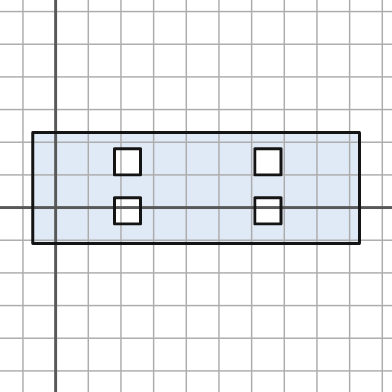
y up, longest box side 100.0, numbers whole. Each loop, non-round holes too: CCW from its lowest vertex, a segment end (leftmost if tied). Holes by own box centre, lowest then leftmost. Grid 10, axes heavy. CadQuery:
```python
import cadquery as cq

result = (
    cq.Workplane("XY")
    .moveTo(-7.0, -11.0)
    .lineTo(93.0, -11.0)
    .lineTo(93.0, 23.0)
    .lineTo(-7.0, 23.0)
    .close()
    .moveTo(18.0, -5.0)
    .lineTo(26.0, -5.0)
    .lineTo(26.0, 3.0)
    .lineTo(18.0, 3.0)
    .close()
    .moveTo(61.0, -5.0)
    .lineTo(69.0, -5.0)
    .lineTo(69.0, 3.0)
    .lineTo(61.0, 3.0)
    .close()
    .moveTo(18.0, 10.0)
    .lineTo(26.0, 10.0)
    .lineTo(26.0, 18.0)
    .lineTo(18.0, 18.0)
    .close()
    .moveTo(61.0, 10.0)
    .lineTo(69.0, 10.0)
    .lineTo(69.0, 18.0)
    .lineTo(61.0, 18.0)
    .close()
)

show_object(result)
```